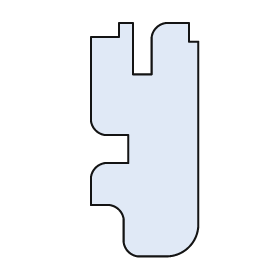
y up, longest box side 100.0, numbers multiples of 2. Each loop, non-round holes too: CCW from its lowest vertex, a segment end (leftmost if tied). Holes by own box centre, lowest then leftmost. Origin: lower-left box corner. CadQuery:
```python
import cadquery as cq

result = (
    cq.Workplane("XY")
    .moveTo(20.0, 0.0)
    .lineTo(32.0, 0.0)
    .threePointArc((42.0, 4.0), (46.0, 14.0))
    .lineTo(46.0, 92.0)
    .lineTo(42.0, 92.0)
    .lineTo(42.0, 100.0)
    .lineTo(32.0, 100.0)
    .threePointArc((28.0, 98.0), (26.0, 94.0))
    .lineTo(26.0, 78.0)
    .lineTo(18.0, 78.0)
    .lineTo(18.0, 100.0)
    .lineTo(12.0, 100.0)
    .lineTo(12.0, 94.0)
    .lineTo(0.0, 94.0)
    .lineTo(0.0, 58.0)
    .threePointArc((2.0, 54.0), (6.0, 52.0))
    .lineTo(16.0, 52.0)
    .lineTo(16.0, 40.0)
    .lineTo(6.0, 40.0)
    .threePointArc((2.0, 38.0), (0.0, 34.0))
    .lineTo(0.0, 22.0)
    .lineTo(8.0, 22.0)
    .threePointArc((12.0, 20.0), (14.0, 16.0))
    .lineTo(14.0, 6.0)
    .threePointArc((16.0, 2.0), (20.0, 0.0))
    .close()
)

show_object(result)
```